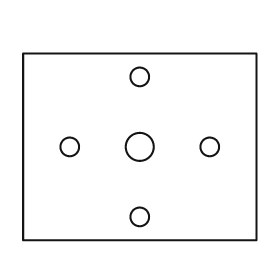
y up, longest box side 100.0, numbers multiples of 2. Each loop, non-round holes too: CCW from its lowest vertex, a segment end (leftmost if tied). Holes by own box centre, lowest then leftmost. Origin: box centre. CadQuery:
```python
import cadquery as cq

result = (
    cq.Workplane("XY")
    .moveTo(-50.0, -40.0)
    .lineTo(50.0, -40.0)
    .lineTo(50.0, 40.0)
    .lineTo(-50.0, 40.0)
    .close()
    .moveTo(0.0, -30.0)
    .circle(4.0)
    .moveTo(-30.0, 0.0)
    .circle(4.0)
    .moveTo(0.0, 0.0)
    .circle(6.0)
    .moveTo(30.0, 0.0)
    .circle(4.0)
    .moveTo(0.0, 30.0)
    .circle(4.0)
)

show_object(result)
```